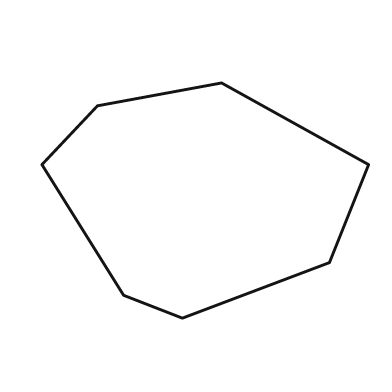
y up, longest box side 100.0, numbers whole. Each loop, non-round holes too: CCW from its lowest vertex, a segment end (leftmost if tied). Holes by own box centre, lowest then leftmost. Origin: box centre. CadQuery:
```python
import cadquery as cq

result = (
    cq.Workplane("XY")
    .moveTo(-7.0, -36.0)
    .lineTo(38.0, -19.0)
    .lineTo(50.0, 11.0)
    .lineTo(5.0, 36.0)
    .lineTo(-33.0, 29.0)
    .lineTo(-50.0, 11.0)
    .lineTo(-25.0, -29.0)
    .close()
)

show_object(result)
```